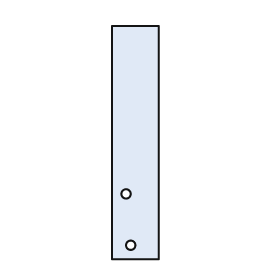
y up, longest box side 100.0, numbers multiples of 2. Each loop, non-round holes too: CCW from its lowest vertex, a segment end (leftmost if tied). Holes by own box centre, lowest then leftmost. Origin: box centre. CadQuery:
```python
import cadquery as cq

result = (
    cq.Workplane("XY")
    .moveTo(-10.0, -50.0)
    .lineTo(10.0, -50.0)
    .lineTo(10.0, 50.0)
    .lineTo(-10.0, 50.0)
    .close()
    .moveTo(-2.0, -44.0)
    .circle(2.0)
    .moveTo(-4.0, -22.0)
    .circle(2.0)
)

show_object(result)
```